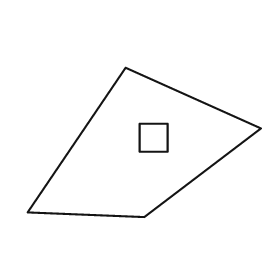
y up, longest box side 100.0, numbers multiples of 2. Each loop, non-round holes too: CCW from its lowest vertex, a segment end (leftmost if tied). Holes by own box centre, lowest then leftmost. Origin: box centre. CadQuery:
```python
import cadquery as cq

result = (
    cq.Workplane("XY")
    .moveTo(0.0, -32.0)
    .lineTo(50.0, 6.0)
    .lineTo(-8.0, 32.0)
    .lineTo(-50.0, -30.0)
    .close()
    .moveTo(-2.0, -4.0)
    .lineTo(10.0, -4.0)
    .lineTo(10.0, 8.0)
    .lineTo(-2.0, 8.0)
    .close()
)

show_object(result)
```